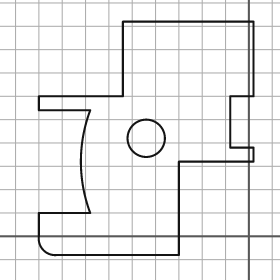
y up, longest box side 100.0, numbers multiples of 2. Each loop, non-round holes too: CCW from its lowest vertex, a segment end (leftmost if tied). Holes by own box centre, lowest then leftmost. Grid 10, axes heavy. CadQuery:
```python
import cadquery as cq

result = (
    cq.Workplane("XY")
    .moveTo(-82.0, -8.0)
    .lineTo(-30.0, -8.0)
    .lineTo(-30.0, 32.0)
    .lineTo(2.0, 32.0)
    .lineTo(2.0, 38.0)
    .lineTo(-8.0, 38.0)
    .lineTo(-8.0, 60.0)
    .lineTo(2.0, 60.0)
    .lineTo(2.0, 92.0)
    .lineTo(-54.0, 92.0)
    .lineTo(-54.0, 60.0)
    .lineTo(-90.0, 60.0)
    .lineTo(-90.0, 54.0)
    .lineTo(-68.0, 54.0)
    .threePointArc((-72.0, 32.0), (-68.0, 10.0))
    .lineTo(-90.0, 10.0)
    .lineTo(-90.0, 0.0)
    .threePointArc((-88.0, -6.0), (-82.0, -8.0))
    .close()
    .moveTo(-44.0, 42.0)
    .circle(8.0)
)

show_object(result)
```